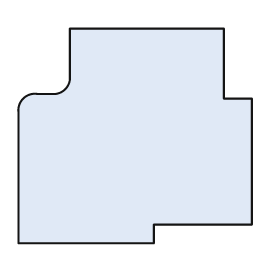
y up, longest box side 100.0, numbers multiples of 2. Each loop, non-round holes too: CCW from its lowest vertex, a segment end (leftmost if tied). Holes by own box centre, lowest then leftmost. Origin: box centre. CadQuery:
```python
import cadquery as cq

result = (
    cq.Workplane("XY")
    .moveTo(-50.0, -46.0)
    .lineTo(8.0, -46.0)
    .lineTo(8.0, -38.0)
    .lineTo(50.0, -38.0)
    .lineTo(50.0, 16.0)
    .lineTo(38.0, 16.0)
    .lineTo(38.0, 46.0)
    .lineTo(-28.0, 46.0)
    .lineTo(-28.0, 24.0)
    .threePointArc((-30.0, 20.0), (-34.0, 18.0))
    .lineTo(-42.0, 18.0)
    .threePointArc((-48.0, 16.0), (-50.0, 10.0))
    .close()
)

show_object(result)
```